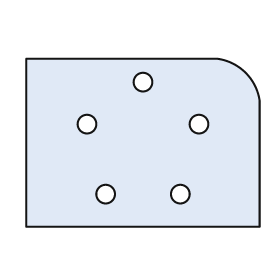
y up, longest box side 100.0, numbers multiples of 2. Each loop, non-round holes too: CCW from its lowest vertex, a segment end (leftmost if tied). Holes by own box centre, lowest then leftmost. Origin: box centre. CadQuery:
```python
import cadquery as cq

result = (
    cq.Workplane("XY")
    .moveTo(-50.0, -36.0)
    .lineTo(50.0, -36.0)
    .lineTo(50.0, 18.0)
    .threePointArc((44.0, 30.0), (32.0, 36.0))
    .lineTo(-50.0, 36.0)
    .close()
    .moveTo(-16.0, -22.0)
    .circle(4.0)
    .moveTo(16.0, -22.0)
    .circle(4.0)
    .moveTo(-24.0, 8.0)
    .circle(4.0)
    .moveTo(24.0, 8.0)
    .circle(4.0)
    .moveTo(0.0, 26.0)
    .circle(4.0)
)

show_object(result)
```